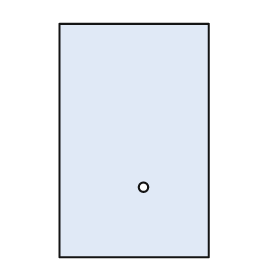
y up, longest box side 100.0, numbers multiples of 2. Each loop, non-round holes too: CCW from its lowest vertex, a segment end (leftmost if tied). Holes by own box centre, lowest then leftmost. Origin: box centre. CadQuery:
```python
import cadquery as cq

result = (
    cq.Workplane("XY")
    .moveTo(-32.0, -50.0)
    .lineTo(32.0, -50.0)
    .lineTo(32.0, 50.0)
    .lineTo(-32.0, 50.0)
    .close()
    .moveTo(4.0, -20.0)
    .circle(2.0)
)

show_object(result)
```